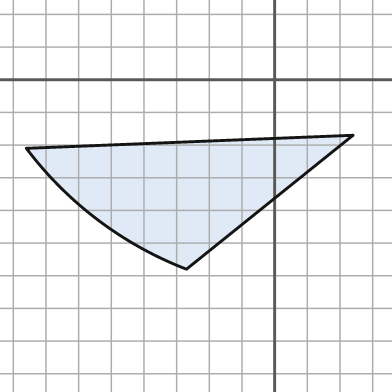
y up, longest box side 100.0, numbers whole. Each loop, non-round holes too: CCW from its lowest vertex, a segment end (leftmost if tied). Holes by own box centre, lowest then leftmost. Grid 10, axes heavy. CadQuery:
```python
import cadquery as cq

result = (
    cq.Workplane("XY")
    .moveTo(-27.0, -58.0)
    .lineTo(24.0, -17.0)
    .lineTo(-76.0, -21.0)
    .threePointArc((-54.0, -43.0), (-27.0, -58.0))
    .close()
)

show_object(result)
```